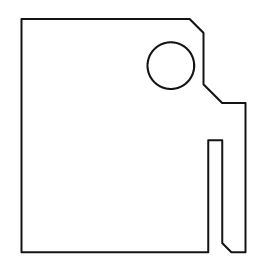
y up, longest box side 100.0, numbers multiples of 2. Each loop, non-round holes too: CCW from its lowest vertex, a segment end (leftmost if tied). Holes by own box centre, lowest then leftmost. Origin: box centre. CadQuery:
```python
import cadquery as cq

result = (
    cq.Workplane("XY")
    .moveTo(-48.0, -50.0)
    .lineTo(32.0, -50.0)
    .lineTo(32.0, -2.0)
    .lineTo(38.0, -2.0)
    .lineTo(38.0, -46.0)
    .lineTo(42.0, -50.0)
    .lineTo(48.0, -50.0)
    .lineTo(48.0, 14.0)
    .lineTo(38.0, 14.0)
    .lineTo(30.0, 22.0)
    .lineTo(30.0, 44.0)
    .lineTo(24.0, 50.0)
    .lineTo(-48.0, 50.0)
    .close()
    .moveTo(16.0, 30.0)
    .circle(10.0)
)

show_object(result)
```